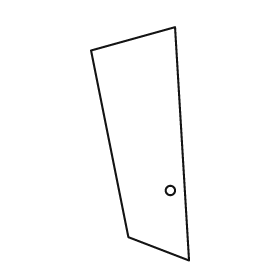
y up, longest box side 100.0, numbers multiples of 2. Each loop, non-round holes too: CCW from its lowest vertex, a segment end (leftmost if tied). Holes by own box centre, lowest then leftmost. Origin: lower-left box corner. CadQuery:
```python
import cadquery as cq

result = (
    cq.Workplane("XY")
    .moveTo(42.0, 0.0)
    .lineTo(36.0, 100.0)
    .lineTo(0.0, 90.0)
    .lineTo(16.0, 10.0)
    .close()
    .moveTo(34.0, 30.0)
    .circle(2.0)
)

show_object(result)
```